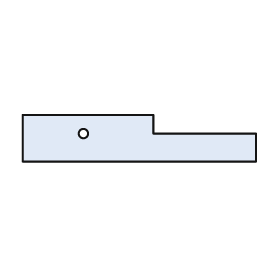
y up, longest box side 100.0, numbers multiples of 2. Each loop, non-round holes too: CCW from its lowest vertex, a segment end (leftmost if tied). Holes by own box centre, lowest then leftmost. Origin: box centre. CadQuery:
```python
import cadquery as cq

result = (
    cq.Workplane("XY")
    .moveTo(-50.0, -10.0)
    .lineTo(50.0, -10.0)
    .lineTo(50.0, 2.0)
    .lineTo(6.0, 2.0)
    .lineTo(6.0, 10.0)
    .lineTo(-50.0, 10.0)
    .close()
    .moveTo(-24.0, 2.0)
    .circle(2.0)
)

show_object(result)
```